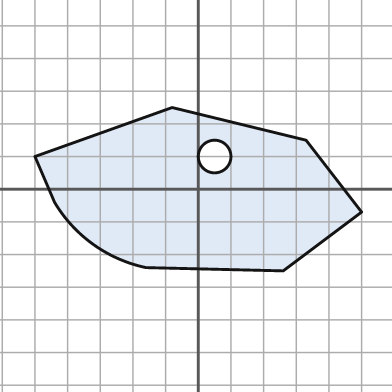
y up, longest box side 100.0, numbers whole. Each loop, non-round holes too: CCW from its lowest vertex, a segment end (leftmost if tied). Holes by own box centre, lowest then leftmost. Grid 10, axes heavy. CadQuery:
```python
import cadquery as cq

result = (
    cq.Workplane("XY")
    .moveTo(26.0, -25.0)
    .lineTo(50.0, -7.0)
    .lineTo(33.0, 15.0)
    .lineTo(-8.0, 25.0)
    .lineTo(-50.0, 10.0)
    .lineTo(-44.0, -4.0)
    .threePointArc((-32.0, -17.0), (-16.0, -24.0))
    .close()
    .moveTo(5.0, 10.0)
    .circle(5.0)
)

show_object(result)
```